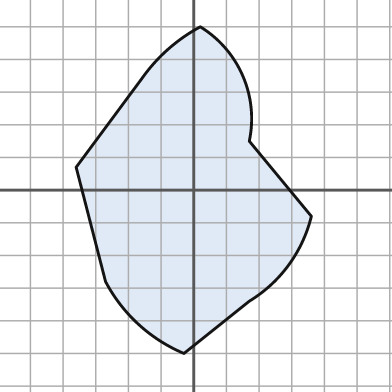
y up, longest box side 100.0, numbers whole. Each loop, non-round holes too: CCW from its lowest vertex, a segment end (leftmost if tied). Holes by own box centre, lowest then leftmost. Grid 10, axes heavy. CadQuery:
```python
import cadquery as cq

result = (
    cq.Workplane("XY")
    .moveTo(-3.0, -50.0)
    .lineTo(17.0, -34.0)
    .threePointArc((29.0, -23.0), (36.0, -8.0))
    .lineTo(17.0, 15.0)
    .threePointArc((15.0, 35.0), (2.0, 50.0))
    .threePointArc((-8.0, 43.0), (-16.0, 34.0))
    .lineTo(-36.0, 7.0)
    .lineTo(-27.0, -28.0)
    .threePointArc((-17.0, -41.0), (-3.0, -50.0))
    .close()
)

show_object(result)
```